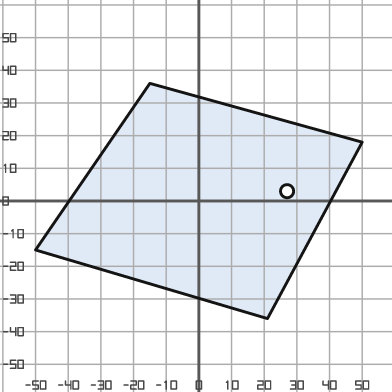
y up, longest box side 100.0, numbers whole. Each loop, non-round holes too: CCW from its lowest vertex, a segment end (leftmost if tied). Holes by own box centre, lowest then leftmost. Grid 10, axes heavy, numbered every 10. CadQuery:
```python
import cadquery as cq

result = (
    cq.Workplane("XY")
    .moveTo(21.0, -36.0)
    .lineTo(50.0, 18.0)
    .lineTo(-15.0, 36.0)
    .lineTo(-50.0, -15.0)
    .close()
    .moveTo(27.0, 3.0)
    .circle(2.0)
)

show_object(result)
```